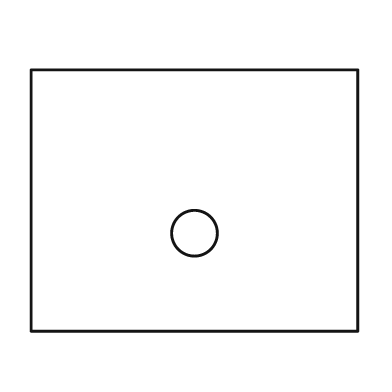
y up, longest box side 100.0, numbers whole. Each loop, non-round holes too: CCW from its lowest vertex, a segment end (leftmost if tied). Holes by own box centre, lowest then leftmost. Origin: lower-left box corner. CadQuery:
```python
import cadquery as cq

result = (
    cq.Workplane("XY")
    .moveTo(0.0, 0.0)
    .lineTo(100.0, 0.0)
    .lineTo(100.0, 80.0)
    .lineTo(0.0, 80.0)
    .close()
    .moveTo(50.0, 30.0)
    .circle(7.0)
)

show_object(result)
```